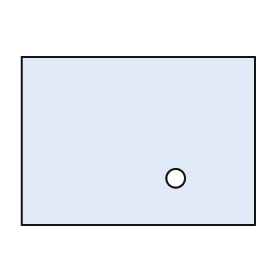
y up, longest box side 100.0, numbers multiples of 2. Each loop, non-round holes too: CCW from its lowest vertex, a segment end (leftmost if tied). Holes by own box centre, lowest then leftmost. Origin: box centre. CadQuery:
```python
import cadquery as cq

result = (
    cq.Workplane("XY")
    .moveTo(-50.0, -36.0)
    .lineTo(50.0, -36.0)
    .lineTo(50.0, 36.0)
    .lineTo(-50.0, 36.0)
    .close()
    .moveTo(16.0, -16.0)
    .circle(4.0)
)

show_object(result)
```